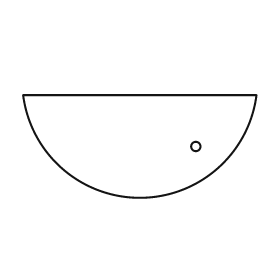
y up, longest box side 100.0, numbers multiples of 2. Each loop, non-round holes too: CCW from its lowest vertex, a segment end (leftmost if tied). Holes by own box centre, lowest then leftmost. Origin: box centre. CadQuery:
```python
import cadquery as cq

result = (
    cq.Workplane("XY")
    .moveTo(-50.0, 22.0)
    .threePointArc((0.0, -22.0), (50.0, 22.0))
    .close()
    .moveTo(24.0, 0.0)
    .circle(2.0)
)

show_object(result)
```